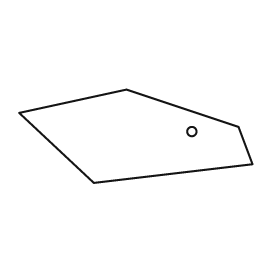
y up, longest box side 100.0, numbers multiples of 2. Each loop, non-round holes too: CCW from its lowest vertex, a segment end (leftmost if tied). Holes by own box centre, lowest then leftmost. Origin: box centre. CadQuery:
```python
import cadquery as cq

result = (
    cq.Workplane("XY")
    .moveTo(-18.0, -20.0)
    .lineTo(50.0, -12.0)
    .lineTo(44.0, 4.0)
    .lineTo(-4.0, 20.0)
    .lineTo(-50.0, 10.0)
    .close()
    .moveTo(24.0, 2.0)
    .circle(2.0)
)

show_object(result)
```